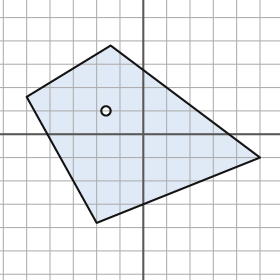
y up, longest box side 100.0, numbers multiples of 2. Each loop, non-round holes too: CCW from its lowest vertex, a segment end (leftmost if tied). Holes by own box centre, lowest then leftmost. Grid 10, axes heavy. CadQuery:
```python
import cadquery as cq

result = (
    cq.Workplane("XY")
    .moveTo(-20.0, -38.0)
    .lineTo(50.0, -10.0)
    .lineTo(-14.0, 38.0)
    .lineTo(-50.0, 16.0)
    .close()
    .moveTo(-16.0, 10.0)
    .circle(2.0)
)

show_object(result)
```